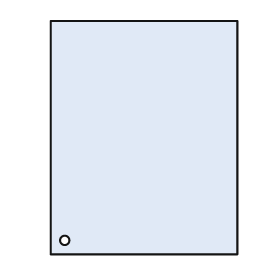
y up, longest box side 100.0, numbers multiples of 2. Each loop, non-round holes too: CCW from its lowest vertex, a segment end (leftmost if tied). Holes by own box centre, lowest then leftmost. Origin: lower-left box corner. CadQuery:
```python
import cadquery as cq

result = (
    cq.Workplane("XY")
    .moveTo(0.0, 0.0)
    .lineTo(80.0, 0.0)
    .lineTo(80.0, 100.0)
    .lineTo(0.0, 100.0)
    .close()
    .moveTo(6.0, 6.0)
    .circle(2.0)
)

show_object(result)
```